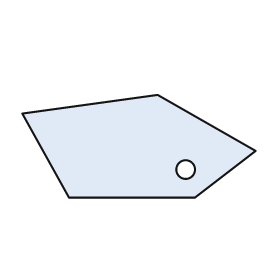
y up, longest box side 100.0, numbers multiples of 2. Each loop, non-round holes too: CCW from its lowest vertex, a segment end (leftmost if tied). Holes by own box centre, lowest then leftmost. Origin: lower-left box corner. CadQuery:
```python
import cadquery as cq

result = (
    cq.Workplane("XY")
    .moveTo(20.0, 0.0)
    .lineTo(74.0, 0.0)
    .lineTo(100.0, 20.0)
    .lineTo(58.0, 44.0)
    .lineTo(0.0, 36.0)
    .close()
    .moveTo(70.0, 12.0)
    .circle(4.0)
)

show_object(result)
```